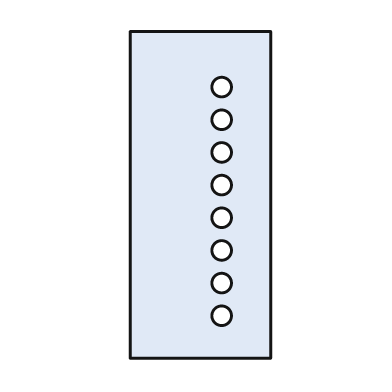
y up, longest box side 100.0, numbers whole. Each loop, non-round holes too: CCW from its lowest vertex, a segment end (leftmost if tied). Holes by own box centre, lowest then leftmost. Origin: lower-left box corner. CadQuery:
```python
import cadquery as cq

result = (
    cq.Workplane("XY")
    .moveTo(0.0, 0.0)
    .lineTo(43.0, 0.0)
    .lineTo(43.0, 100.0)
    .lineTo(0.0, 100.0)
    .close()
    .moveTo(28.0, 13.0)
    .circle(3.0)
    .moveTo(28.0, 23.0)
    .circle(3.0)
    .moveTo(28.0, 33.0)
    .circle(3.0)
    .moveTo(28.0, 43.0)
    .circle(3.0)
    .moveTo(28.0, 53.0)
    .circle(3.0)
    .moveTo(28.0, 63.0)
    .circle(3.0)
    .moveTo(28.0, 73.0)
    .circle(3.0)
    .moveTo(28.0, 83.0)
    .circle(3.0)
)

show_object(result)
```